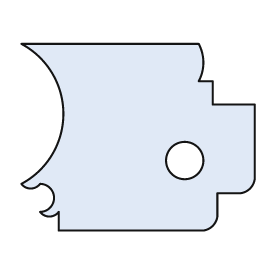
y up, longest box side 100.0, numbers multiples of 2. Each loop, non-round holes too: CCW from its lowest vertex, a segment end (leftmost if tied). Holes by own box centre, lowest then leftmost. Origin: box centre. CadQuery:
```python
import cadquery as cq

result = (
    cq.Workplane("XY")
    .moveTo(-34.0, -40.0)
    .lineTo(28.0, -40.0)
    .threePointArc((32.0, -38.0), (34.0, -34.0))
    .lineTo(34.0, -24.0)
    .lineTo(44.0, -24.0)
    .threePointArc((48.0, -22.0), (50.0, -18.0))
    .lineTo(50.0, 14.0)
    .lineTo(32.0, 14.0)
    .lineTo(32.0, 24.0)
    .lineTo(26.0, 24.0)
    .threePointArc((28.0, 32.0), (26.0, 40.0))
    .lineTo(-50.0, 40.0)
    .threePointArc((-32.0, 10.0), (-50.0, -20.0))
    .threePointArc((-46.0, -22.0), (-42.0, -20.0))
    .threePointArc((-36.0, -26.0), (-42.0, -32.0))
    .threePointArc((-38.0, -34.0), (-34.0, -32.0))
    .close()
    .moveTo(20.0, -10.0)
    .circle(8.0)
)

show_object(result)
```